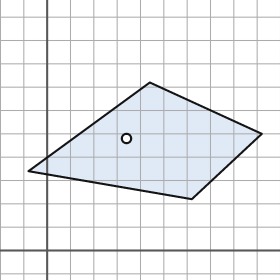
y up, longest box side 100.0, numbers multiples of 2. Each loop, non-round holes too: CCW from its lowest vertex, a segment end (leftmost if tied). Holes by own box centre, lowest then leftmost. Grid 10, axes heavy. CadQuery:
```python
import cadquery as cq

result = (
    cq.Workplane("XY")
    .moveTo(62.0, 22.0)
    .lineTo(92.0, 50.0)
    .lineTo(44.0, 72.0)
    .lineTo(-8.0, 34.0)
    .close()
    .moveTo(34.0, 48.0)
    .circle(2.0)
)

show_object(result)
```